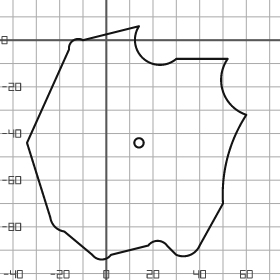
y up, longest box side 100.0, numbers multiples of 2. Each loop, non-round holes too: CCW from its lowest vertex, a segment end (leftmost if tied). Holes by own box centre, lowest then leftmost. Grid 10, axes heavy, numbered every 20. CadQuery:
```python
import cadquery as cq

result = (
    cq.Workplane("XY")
    .moveTo(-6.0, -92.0)
    .threePointArc((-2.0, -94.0), (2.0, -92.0))
    .lineTo(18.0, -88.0)
    .threePointArc((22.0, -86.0), (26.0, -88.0))
    .lineTo(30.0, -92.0)
    .threePointArc((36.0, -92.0), (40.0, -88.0))
    .lineTo(50.0, -70.0)
    .threePointArc((52.0, -50.0), (60.0, -32.0))
    .threePointArc((50.0, -22.0), (52.0, -8.0))
    .lineTo(30.0, -8.0)
    .threePointArc((16.0, -8.0), (14.0, 6.0))
    .lineTo(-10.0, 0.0)
    .threePointArc((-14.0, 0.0), (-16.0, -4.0))
    .lineTo(-34.0, -44.0)
    .lineTo(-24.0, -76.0)
    .threePointArc((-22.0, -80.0), (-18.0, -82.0))
    .close()
    .moveTo(14.0, -44.0)
    .circle(2.0)
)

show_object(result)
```